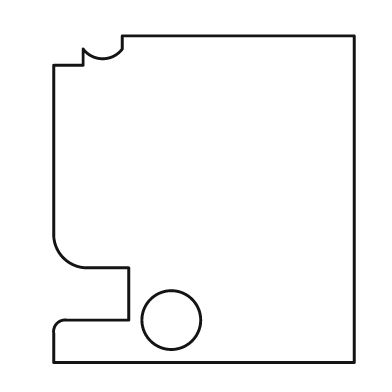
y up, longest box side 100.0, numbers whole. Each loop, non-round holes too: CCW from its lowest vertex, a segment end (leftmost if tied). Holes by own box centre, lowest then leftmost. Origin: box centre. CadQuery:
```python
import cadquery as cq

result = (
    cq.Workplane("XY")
    .moveTo(-46.0, -50.0)
    .lineTo(46.0, -50.0)
    .lineTo(46.0, 50.0)
    .lineTo(-25.0, 50.0)
    .lineTo(-25.0, 46.0)
    .threePointArc((-31.0, 43.0), (-37.0, 46.0))
    .lineTo(-37.0, 41.0)
    .lineTo(-46.0, 41.0)
    .lineTo(-46.0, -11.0)
    .threePointArc((-43.0, -18.0), (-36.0, -21.0))
    .lineTo(-23.0, -21.0)
    .lineTo(-23.0, -37.0)
    .lineTo(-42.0, -37.0)
    .threePointArc((-45.0, -38.0), (-46.0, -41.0))
    .close()
    .moveTo(-10.0, -37.0)
    .circle(9.0)
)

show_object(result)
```